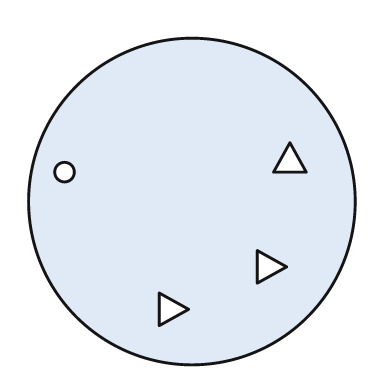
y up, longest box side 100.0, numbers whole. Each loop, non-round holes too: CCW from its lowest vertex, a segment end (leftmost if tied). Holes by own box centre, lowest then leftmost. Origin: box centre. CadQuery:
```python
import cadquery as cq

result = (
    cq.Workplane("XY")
    .moveTo(0.0, 0.0)
    .circle(50.0)
    .moveTo(-10.0, -38.0)
    .lineTo(-1.0, -33.0)
    .lineTo(-10.0, -28.0)
    .close()
    .moveTo(20.0, -25.0)
    .lineTo(29.0, -20.0)
    .lineTo(20.0, -15.0)
    .close()
    .moveTo(-39.0, 9.0)
    .circle(3.0)
    .moveTo(25.0, 9.0)
    .lineTo(35.0, 9.0)
    .lineTo(30.0, 18.0)
    .close()
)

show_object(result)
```